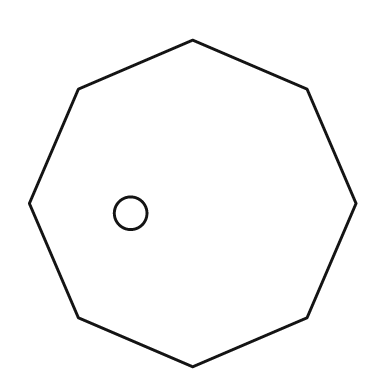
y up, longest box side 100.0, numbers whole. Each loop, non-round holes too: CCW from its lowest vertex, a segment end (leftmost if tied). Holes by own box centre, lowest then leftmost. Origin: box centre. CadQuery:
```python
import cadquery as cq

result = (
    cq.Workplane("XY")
    .moveTo(0.0, -50.0)
    .lineTo(35.0, -35.0)
    .lineTo(50.0, 0.0)
    .lineTo(35.0, 35.0)
    .lineTo(0.0, 50.0)
    .lineTo(-35.0, 35.0)
    .lineTo(-50.0, 0.0)
    .lineTo(-35.0, -35.0)
    .close()
    .moveTo(-19.0, -3.0)
    .circle(5.0)
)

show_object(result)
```